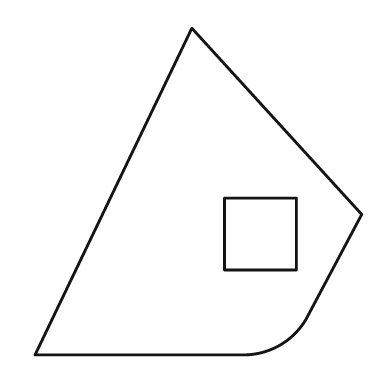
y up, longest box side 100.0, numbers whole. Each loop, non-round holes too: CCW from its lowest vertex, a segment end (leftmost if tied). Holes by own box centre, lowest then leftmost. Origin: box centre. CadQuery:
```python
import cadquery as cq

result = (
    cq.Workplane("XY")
    .moveTo(-50.0, -50.0)
    .lineTo(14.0, -50.0)
    .threePointArc((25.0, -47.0), (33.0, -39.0))
    .lineTo(50.0, -7.0)
    .lineTo(-2.0, 50.0)
    .close()
    .moveTo(8.0, -24.0)
    .lineTo(30.0, -24.0)
    .lineTo(30.0, -2.0)
    .lineTo(8.0, -2.0)
    .close()
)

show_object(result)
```